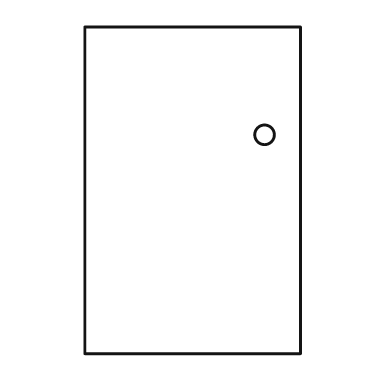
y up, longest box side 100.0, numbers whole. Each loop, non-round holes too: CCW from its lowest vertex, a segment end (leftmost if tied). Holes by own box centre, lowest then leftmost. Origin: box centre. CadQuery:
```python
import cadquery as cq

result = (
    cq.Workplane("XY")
    .moveTo(-33.0, -50.0)
    .lineTo(33.0, -50.0)
    .lineTo(33.0, 50.0)
    .lineTo(-33.0, 50.0)
    .close()
    .moveTo(22.0, 17.0)
    .circle(3.0)
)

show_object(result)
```